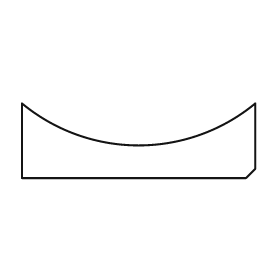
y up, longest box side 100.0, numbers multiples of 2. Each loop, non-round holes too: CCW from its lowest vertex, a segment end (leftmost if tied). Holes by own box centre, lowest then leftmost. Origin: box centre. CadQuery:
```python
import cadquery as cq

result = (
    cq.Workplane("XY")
    .moveTo(-50.0, -16.0)
    .lineTo(46.0, -16.0)
    .lineTo(50.0, -12.0)
    .lineTo(50.0, 16.0)
    .threePointArc((0.0, -2.0), (-50.0, 16.0))
    .close()
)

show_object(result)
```